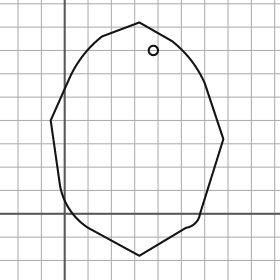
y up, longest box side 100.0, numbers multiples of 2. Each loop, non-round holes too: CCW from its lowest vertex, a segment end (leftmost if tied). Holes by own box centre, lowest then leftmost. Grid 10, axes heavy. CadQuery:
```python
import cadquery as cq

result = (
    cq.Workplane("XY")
    .moveTo(32.0, -18.0)
    .lineTo(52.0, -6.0)
    .threePointArc((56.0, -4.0), (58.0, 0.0))
    .lineTo(68.0, 32.0)
    .lineTo(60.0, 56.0)
    .threePointArc((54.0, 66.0), (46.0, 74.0))
    .lineTo(32.0, 82.0)
    .lineTo(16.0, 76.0)
    .threePointArc((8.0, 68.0), (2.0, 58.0))
    .lineTo(-6.0, 40.0)
    .lineTo(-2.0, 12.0)
    .threePointArc((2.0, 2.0), (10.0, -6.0))
    .close()
    .moveTo(38.0, 70.0)
    .circle(2.0)
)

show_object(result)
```